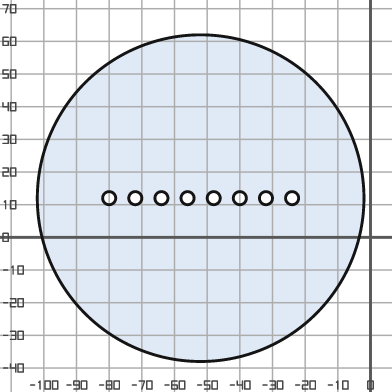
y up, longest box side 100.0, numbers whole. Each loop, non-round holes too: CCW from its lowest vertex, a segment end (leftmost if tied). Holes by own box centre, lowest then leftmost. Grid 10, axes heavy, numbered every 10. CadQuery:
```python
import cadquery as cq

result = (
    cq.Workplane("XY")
    .moveTo(-52.0, 12.0)
    .circle(50.0)
    .moveTo(-80.0, 12.0)
    .circle(2.0)
    .moveTo(-72.0, 12.0)
    .circle(2.0)
    .moveTo(-64.0, 12.0)
    .circle(2.0)
    .moveTo(-56.0, 12.0)
    .circle(2.0)
    .moveTo(-48.0, 12.0)
    .circle(2.0)
    .moveTo(-40.0, 12.0)
    .circle(2.0)
    .moveTo(-32.0, 12.0)
    .circle(2.0)
    .moveTo(-24.0, 12.0)
    .circle(2.0)
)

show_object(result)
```